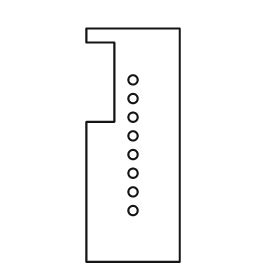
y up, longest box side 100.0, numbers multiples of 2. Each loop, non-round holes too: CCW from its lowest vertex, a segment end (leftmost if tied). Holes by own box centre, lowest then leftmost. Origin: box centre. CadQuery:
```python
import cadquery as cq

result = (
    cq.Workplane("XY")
    .moveTo(-20.0, -50.0)
    .lineTo(20.0, -50.0)
    .lineTo(20.0, 50.0)
    .lineTo(-20.0, 50.0)
    .lineTo(-20.0, 44.0)
    .lineTo(-8.0, 44.0)
    .lineTo(-8.0, 10.0)
    .lineTo(-20.0, 10.0)
    .close()
    .moveTo(0.0, -28.0)
    .circle(2.0)
    .moveTo(0.0, -20.0)
    .circle(2.0)
    .moveTo(0.0, -12.0)
    .circle(2.0)
    .moveTo(0.0, -4.0)
    .circle(2.0)
    .moveTo(0.0, 4.0)
    .circle(2.0)
    .moveTo(0.0, 12.0)
    .circle(2.0)
    .moveTo(0.0, 20.0)
    .circle(2.0)
    .moveTo(0.0, 28.0)
    .circle(2.0)
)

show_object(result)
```